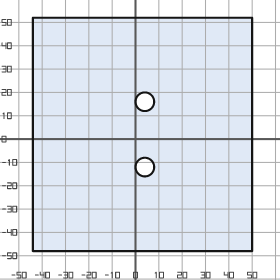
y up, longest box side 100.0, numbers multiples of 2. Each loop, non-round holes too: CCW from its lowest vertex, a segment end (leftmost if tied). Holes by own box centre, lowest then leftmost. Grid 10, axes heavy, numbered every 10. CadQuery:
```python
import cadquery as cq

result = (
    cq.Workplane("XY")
    .moveTo(-44.0, -48.0)
    .lineTo(50.0, -48.0)
    .lineTo(50.0, 52.0)
    .lineTo(-44.0, 52.0)
    .close()
    .moveTo(4.0, -12.0)
    .circle(4.0)
    .moveTo(4.0, 16.0)
    .circle(4.0)
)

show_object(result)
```